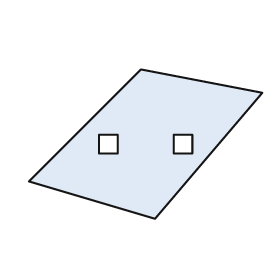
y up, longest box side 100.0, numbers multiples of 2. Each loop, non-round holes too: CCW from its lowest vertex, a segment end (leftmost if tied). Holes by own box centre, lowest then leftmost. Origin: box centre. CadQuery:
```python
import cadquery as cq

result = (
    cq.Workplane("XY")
    .moveTo(4.0, -32.0)
    .lineTo(50.0, 22.0)
    .lineTo(-2.0, 32.0)
    .lineTo(-50.0, -16.0)
    .close()
    .moveTo(-20.0, -4.0)
    .lineTo(-12.0, -4.0)
    .lineTo(-12.0, 4.0)
    .lineTo(-20.0, 4.0)
    .close()
    .moveTo(12.0, -4.0)
    .lineTo(20.0, -4.0)
    .lineTo(20.0, 4.0)
    .lineTo(12.0, 4.0)
    .close()
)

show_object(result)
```